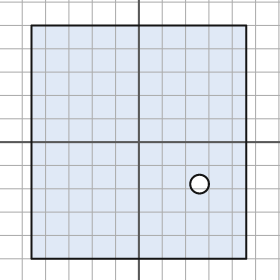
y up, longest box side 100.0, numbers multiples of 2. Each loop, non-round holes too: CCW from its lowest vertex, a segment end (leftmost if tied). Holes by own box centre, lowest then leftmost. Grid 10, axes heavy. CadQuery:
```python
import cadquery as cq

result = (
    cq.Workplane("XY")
    .moveTo(-46.0, -50.0)
    .lineTo(46.0, -50.0)
    .lineTo(46.0, 50.0)
    .lineTo(-46.0, 50.0)
    .close()
    .moveTo(26.0, -18.0)
    .circle(4.0)
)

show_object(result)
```